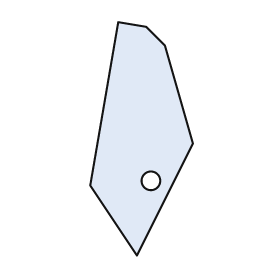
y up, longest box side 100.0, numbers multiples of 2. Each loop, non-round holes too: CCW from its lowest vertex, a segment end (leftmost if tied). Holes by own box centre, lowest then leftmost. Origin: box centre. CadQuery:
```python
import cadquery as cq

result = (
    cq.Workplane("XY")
    .moveTo(-2.0, -50.0)
    .lineTo(22.0, -2.0)
    .lineTo(10.0, 40.0)
    .lineTo(2.0, 48.0)
    .lineTo(-10.0, 50.0)
    .lineTo(-22.0, -20.0)
    .close()
    .moveTo(4.0, -18.0)
    .circle(4.0)
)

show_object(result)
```